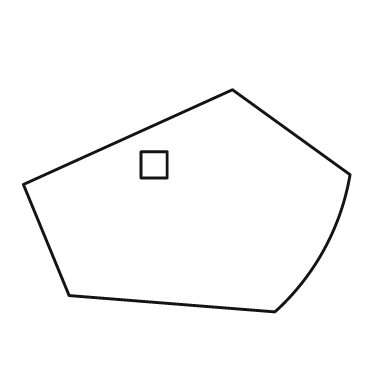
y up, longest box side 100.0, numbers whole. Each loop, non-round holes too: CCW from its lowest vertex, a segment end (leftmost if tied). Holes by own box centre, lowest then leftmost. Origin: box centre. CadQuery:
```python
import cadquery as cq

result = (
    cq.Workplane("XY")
    .moveTo(27.0, -34.0)
    .threePointArc((42.0, -15.0), (50.0, 8.0))
    .lineTo(14.0, 34.0)
    .lineTo(-50.0, 5.0)
    .lineTo(-36.0, -29.0)
    .close()
    .moveTo(-14.0, 7.0)
    .lineTo(-6.0, 7.0)
    .lineTo(-6.0, 15.0)
    .lineTo(-14.0, 15.0)
    .close()
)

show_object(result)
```